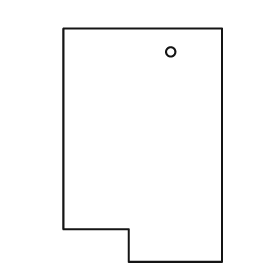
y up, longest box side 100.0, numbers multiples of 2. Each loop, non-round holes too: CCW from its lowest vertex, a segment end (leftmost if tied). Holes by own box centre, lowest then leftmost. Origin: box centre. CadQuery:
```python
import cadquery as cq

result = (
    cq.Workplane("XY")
    .moveTo(-6.0, -50.0)
    .lineTo(34.0, -50.0)
    .lineTo(34.0, 50.0)
    .lineTo(-34.0, 50.0)
    .lineTo(-34.0, -36.0)
    .lineTo(-6.0, -36.0)
    .close()
    .moveTo(12.0, 40.0)
    .circle(2.0)
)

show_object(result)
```